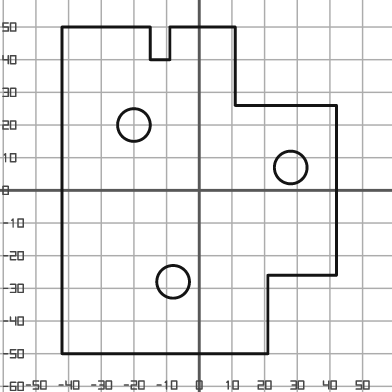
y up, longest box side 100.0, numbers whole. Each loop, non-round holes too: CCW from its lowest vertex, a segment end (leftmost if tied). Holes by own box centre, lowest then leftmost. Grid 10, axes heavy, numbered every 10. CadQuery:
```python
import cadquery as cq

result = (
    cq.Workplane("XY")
    .moveTo(-42.0, -50.0)
    .lineTo(21.0, -50.0)
    .lineTo(21.0, -26.0)
    .lineTo(42.0, -26.0)
    .lineTo(42.0, 26.0)
    .lineTo(11.0, 26.0)
    .lineTo(11.0, 50.0)
    .lineTo(-9.0, 50.0)
    .lineTo(-9.0, 40.0)
    .lineTo(-15.0, 40.0)
    .lineTo(-15.0, 50.0)
    .lineTo(-42.0, 50.0)
    .close()
    .moveTo(-8.0, -28.0)
    .circle(5.0)
    .moveTo(28.0, 7.0)
    .circle(5.0)
    .moveTo(-20.0, 20.0)
    .circle(5.0)
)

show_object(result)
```